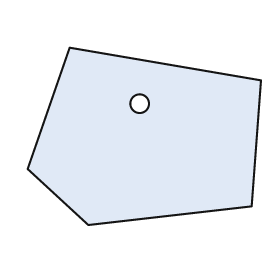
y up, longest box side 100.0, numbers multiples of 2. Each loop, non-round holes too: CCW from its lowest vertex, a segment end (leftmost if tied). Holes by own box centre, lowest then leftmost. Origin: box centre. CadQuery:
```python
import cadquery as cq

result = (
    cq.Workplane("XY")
    .moveTo(-24.0, -38.0)
    .lineTo(46.0, -30.0)
    .lineTo(50.0, 24.0)
    .lineTo(-32.0, 38.0)
    .lineTo(-50.0, -14.0)
    .close()
    .moveTo(-2.0, 14.0)
    .circle(4.0)
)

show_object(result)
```